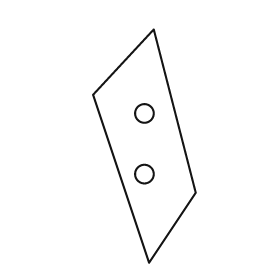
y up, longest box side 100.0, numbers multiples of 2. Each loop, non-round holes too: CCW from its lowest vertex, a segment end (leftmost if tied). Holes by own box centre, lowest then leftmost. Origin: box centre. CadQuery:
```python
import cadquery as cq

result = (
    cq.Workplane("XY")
    .moveTo(2.0, -50.0)
    .lineTo(22.0, -20.0)
    .lineTo(4.0, 50.0)
    .lineTo(-22.0, 22.0)
    .close()
    .moveTo(0.0, -12.0)
    .circle(4.0)
    .moveTo(0.0, 14.0)
    .circle(4.0)
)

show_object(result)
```